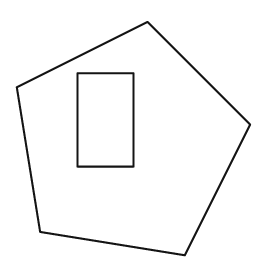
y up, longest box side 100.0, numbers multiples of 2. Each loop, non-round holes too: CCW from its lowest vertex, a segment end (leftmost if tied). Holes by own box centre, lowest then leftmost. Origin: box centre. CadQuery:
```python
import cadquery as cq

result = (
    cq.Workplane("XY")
    .moveTo(22.0, -50.0)
    .lineTo(50.0, 6.0)
    .lineTo(6.0, 50.0)
    .lineTo(-50.0, 22.0)
    .lineTo(-40.0, -40.0)
    .close()
    .moveTo(-24.0, -12.0)
    .lineTo(0.0, -12.0)
    .lineTo(0.0, 28.0)
    .lineTo(-24.0, 28.0)
    .close()
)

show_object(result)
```